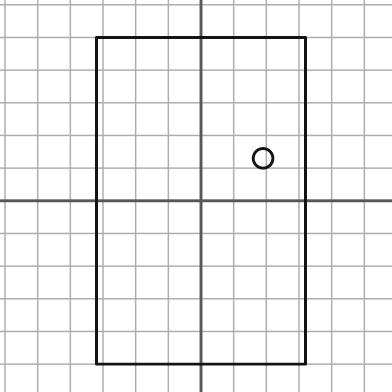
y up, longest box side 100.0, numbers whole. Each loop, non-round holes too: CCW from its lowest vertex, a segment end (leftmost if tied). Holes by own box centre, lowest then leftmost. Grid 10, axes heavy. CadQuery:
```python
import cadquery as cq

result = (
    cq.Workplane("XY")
    .moveTo(-32.0, -50.0)
    .lineTo(32.0, -50.0)
    .lineTo(32.0, 50.0)
    .lineTo(-32.0, 50.0)
    .close()
    .moveTo(19.0, 13.0)
    .circle(3.0)
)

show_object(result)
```